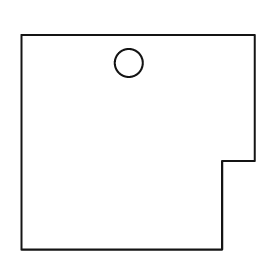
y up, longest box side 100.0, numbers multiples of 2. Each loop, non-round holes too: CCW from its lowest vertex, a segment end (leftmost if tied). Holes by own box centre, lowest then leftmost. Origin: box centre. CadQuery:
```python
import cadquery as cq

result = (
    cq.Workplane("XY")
    .moveTo(-50.0, -46.0)
    .lineTo(36.0, -46.0)
    .lineTo(36.0, -8.0)
    .lineTo(50.0, -8.0)
    .lineTo(50.0, 46.0)
    .lineTo(-50.0, 46.0)
    .close()
    .moveTo(-4.0, 34.0)
    .circle(6.0)
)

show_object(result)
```